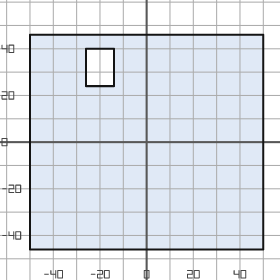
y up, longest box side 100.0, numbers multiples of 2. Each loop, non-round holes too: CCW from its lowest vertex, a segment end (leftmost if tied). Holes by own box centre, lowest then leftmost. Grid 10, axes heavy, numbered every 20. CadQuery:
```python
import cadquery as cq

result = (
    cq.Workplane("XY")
    .moveTo(-50.0, -46.0)
    .lineTo(50.0, -46.0)
    .lineTo(50.0, 46.0)
    .lineTo(-50.0, 46.0)
    .close()
    .moveTo(-26.0, 24.0)
    .lineTo(-14.0, 24.0)
    .lineTo(-14.0, 40.0)
    .lineTo(-26.0, 40.0)
    .close()
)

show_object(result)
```